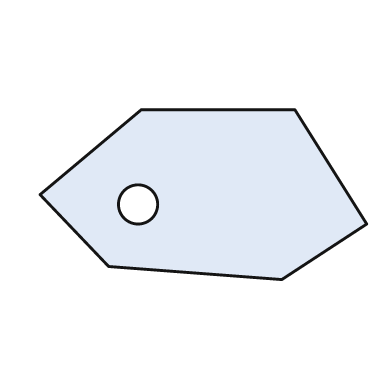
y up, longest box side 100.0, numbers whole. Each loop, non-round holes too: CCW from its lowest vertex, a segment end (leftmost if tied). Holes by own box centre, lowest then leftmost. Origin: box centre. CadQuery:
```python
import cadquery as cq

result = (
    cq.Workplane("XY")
    .moveTo(24.0, -26.0)
    .lineTo(50.0, -9.0)
    .lineTo(28.0, 26.0)
    .lineTo(-19.0, 26.0)
    .lineTo(-50.0, 0.0)
    .lineTo(-29.0, -22.0)
    .close()
    .moveTo(-20.0, -3.0)
    .circle(6.0)
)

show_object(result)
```